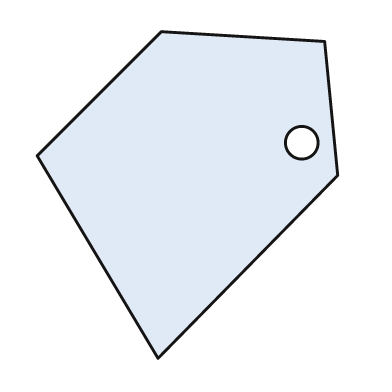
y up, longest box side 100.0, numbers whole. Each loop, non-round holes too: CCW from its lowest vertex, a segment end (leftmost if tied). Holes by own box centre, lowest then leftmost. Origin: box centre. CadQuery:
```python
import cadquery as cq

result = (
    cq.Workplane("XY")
    .moveTo(-9.0, -50.0)
    .lineTo(46.0, 6.0)
    .lineTo(42.0, 47.0)
    .lineTo(-8.0, 50.0)
    .lineTo(-46.0, 12.0)
    .close()
    .moveTo(35.0, 16.0)
    .circle(5.0)
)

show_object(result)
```